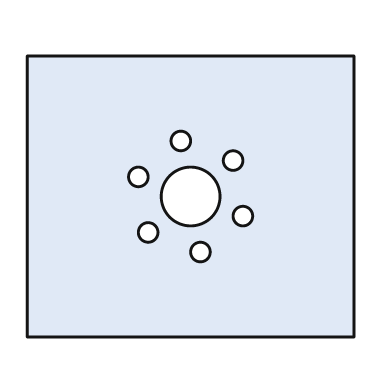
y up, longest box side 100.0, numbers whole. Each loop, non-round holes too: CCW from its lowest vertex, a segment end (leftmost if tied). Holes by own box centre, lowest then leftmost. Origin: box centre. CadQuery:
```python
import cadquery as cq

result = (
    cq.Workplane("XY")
    .moveTo(-50.0, -43.0)
    .lineTo(50.0, -43.0)
    .lineTo(50.0, 43.0)
    .lineTo(-50.0, 43.0)
    .close()
    .moveTo(3.0, -17.0)
    .circle(3.0)
    .moveTo(-13.0, -11.0)
    .circle(3.0)
    .moveTo(16.0, -6.0)
    .circle(3.0)
    .moveTo(0.0, 0.0)
    .circle(9.0)
    .moveTo(-16.0, 6.0)
    .circle(3.0)
    .moveTo(13.0, 11.0)
    .circle(3.0)
    .moveTo(-3.0, 17.0)
    .circle(3.0)
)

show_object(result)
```